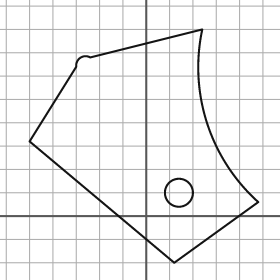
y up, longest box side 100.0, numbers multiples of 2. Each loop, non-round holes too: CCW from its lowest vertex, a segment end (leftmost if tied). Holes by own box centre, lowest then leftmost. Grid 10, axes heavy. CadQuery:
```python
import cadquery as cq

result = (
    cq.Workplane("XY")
    .moveTo(12.0, -20.0)
    .lineTo(48.0, 6.0)
    .threePointArc((26.0, 40.0), (24.0, 80.0))
    .lineTo(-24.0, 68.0)
    .threePointArc((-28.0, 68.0), (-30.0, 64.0))
    .lineTo(-50.0, 32.0)
    .close()
    .moveTo(14.0, 10.0)
    .circle(6.0)
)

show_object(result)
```